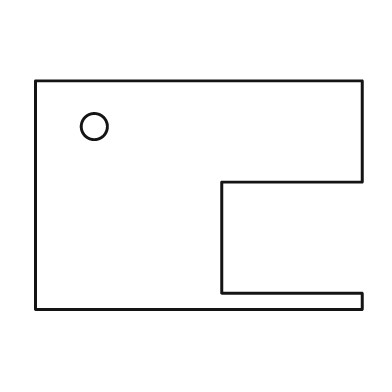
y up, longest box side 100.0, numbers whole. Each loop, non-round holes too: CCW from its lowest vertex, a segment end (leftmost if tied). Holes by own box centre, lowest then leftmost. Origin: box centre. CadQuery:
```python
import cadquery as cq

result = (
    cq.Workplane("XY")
    .moveTo(-50.0, -35.0)
    .lineTo(50.0, -35.0)
    .lineTo(50.0, -30.0)
    .lineTo(7.0, -30.0)
    .lineTo(7.0, 4.0)
    .lineTo(50.0, 4.0)
    .lineTo(50.0, 35.0)
    .lineTo(-50.0, 35.0)
    .close()
    .moveTo(-32.0, 21.0)
    .circle(4.0)
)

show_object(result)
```